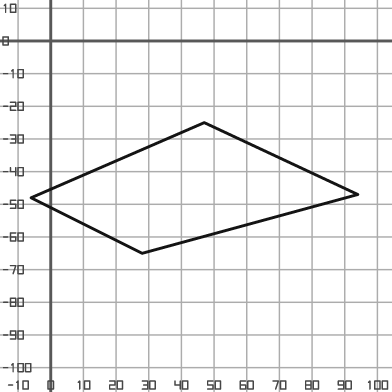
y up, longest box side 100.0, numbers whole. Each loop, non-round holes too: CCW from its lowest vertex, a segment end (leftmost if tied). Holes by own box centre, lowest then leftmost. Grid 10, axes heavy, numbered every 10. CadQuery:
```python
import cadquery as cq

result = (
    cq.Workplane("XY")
    .moveTo(28.0, -65.0)
    .lineTo(94.0, -47.0)
    .lineTo(47.0, -25.0)
    .lineTo(-6.0, -48.0)
    .close()
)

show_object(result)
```